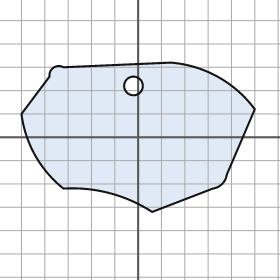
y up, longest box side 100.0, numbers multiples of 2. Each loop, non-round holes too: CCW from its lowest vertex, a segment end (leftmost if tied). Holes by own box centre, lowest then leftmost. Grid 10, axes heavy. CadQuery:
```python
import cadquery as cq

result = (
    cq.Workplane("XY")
    .moveTo(6.0, -32.0)
    .lineTo(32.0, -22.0)
    .threePointArc((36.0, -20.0), (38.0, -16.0))
    .lineTo(50.0, 12.0)
    .threePointArc((34.0, 26.0), (14.0, 32.0))
    .lineTo(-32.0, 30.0)
    .threePointArc((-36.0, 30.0), (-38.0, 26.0))
    .lineTo(-50.0, 10.0)
    .threePointArc((-44.0, -8.0), (-32.0, -22.0))
    .threePointArc((-12.0, -24.0), (6.0, -32.0))
    .close()
    .moveTo(-2.0, 22.0)
    .circle(4.0)
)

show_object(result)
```